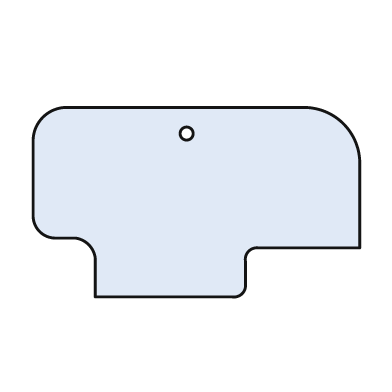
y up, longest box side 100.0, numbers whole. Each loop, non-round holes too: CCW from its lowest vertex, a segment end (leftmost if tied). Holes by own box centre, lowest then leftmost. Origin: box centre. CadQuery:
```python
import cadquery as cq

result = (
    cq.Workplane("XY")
    .moveTo(-31.0, -29.0)
    .lineTo(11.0, -29.0)
    .threePointArc((14.0, -28.0), (15.0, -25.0))
    .lineTo(15.0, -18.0)
    .threePointArc((16.0, -15.0), (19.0, -14.0))
    .lineTo(50.0, -14.0)
    .lineTo(50.0, 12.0)
    .threePointArc((45.0, 24.0), (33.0, 29.0))
    .lineTo(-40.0, 29.0)
    .threePointArc((-47.0, 26.0), (-50.0, 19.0))
    .lineTo(-50.0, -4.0)
    .threePointArc((-48.0, -9.0), (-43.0, -11.0))
    .lineTo(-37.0, -11.0)
    .threePointArc((-33.0, -13.0), (-31.0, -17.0))
    .close()
    .moveTo(-3.0, 21.0)
    .circle(2.0)
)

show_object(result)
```